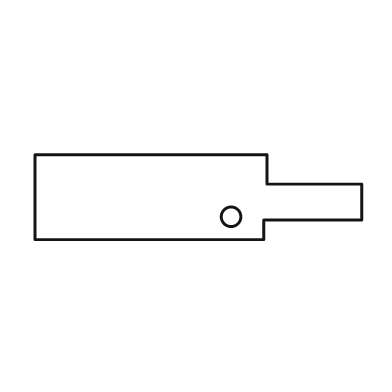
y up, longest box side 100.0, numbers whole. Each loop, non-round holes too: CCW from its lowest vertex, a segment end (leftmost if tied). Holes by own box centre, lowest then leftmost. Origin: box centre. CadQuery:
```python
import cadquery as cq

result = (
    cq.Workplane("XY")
    .moveTo(-50.0, -13.0)
    .lineTo(20.0, -13.0)
    .lineTo(20.0, -7.0)
    .lineTo(50.0, -7.0)
    .lineTo(50.0, 4.0)
    .lineTo(21.0, 4.0)
    .lineTo(21.0, 13.0)
    .lineTo(-50.0, 13.0)
    .close()
    .moveTo(10.0, -6.0)
    .circle(3.0)
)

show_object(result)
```